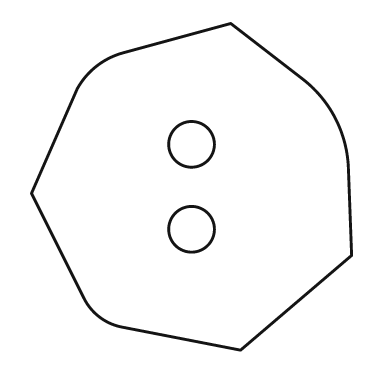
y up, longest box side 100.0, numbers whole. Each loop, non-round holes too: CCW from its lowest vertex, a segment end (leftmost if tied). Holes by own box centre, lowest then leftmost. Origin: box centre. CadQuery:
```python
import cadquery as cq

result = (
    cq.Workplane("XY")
    .moveTo(15.0, -50.0)
    .lineTo(49.0, -21.0)
    .lineTo(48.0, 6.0)
    .threePointArc((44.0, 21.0), (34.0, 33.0))
    .lineTo(12.0, 50.0)
    .lineTo(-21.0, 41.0)
    .threePointArc((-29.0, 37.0), (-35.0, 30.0))
    .lineTo(-49.0, -2.0)
    .lineTo(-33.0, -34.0)
    .threePointArc((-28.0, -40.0), (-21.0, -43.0))
    .close()
    .moveTo(0.0, -13.0)
    .circle(7.0)
    .moveTo(0.0, 13.0)
    .circle(7.0)
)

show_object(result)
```